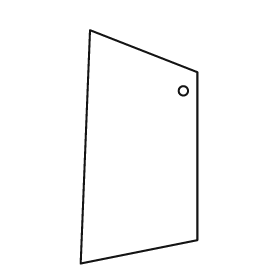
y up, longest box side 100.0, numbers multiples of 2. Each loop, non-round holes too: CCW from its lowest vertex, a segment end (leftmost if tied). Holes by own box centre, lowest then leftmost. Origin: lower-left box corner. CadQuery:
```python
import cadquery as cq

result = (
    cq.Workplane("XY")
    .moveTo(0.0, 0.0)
    .lineTo(50.0, 10.0)
    .lineTo(50.0, 82.0)
    .lineTo(4.0, 100.0)
    .close()
    .moveTo(44.0, 74.0)
    .circle(2.0)
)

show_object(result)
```